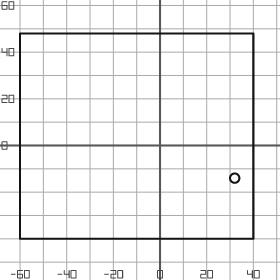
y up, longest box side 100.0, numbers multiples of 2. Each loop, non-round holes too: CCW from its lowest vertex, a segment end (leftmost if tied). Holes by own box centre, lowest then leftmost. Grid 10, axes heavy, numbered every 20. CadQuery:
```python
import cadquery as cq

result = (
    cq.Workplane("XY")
    .moveTo(-60.0, -40.0)
    .lineTo(40.0, -40.0)
    .lineTo(40.0, 48.0)
    .lineTo(-60.0, 48.0)
    .close()
    .moveTo(32.0, -14.0)
    .circle(2.0)
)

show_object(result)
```